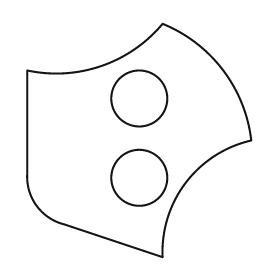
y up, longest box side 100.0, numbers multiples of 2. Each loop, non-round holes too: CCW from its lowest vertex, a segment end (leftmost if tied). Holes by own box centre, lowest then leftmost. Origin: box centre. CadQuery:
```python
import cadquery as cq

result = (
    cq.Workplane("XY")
    .moveTo(10.0, -50.0)
    .threePointArc((20.0, -18.0), (48.0, 0.0))
    .threePointArc((36.0, 30.0), (10.0, 50.0))
    .threePointArc((-16.0, 32.0), (-48.0, 30.0))
    .lineTo(-48.0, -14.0)
    .threePointArc((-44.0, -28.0), (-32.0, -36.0))
    .close()
    .moveTo(0.0, -16.0)
    .circle(12.0)
    .moveTo(0.0, 18.0)
    .circle(12.0)
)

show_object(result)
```